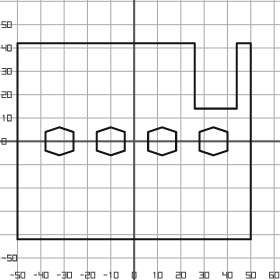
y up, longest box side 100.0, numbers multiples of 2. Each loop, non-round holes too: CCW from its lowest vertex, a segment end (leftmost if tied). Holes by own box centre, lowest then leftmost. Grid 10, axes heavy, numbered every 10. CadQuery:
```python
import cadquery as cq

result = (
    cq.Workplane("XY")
    .moveTo(-50.0, -42.0)
    .lineTo(50.0, -42.0)
    .lineTo(50.0, 42.0)
    .lineTo(44.0, 42.0)
    .lineTo(44.0, 14.0)
    .lineTo(26.0, 14.0)
    .lineTo(26.0, 42.0)
    .lineTo(-50.0, 42.0)
    .close()
    .moveTo(-32.0, -6.0)
    .lineTo(-26.0, -4.0)
    .lineTo(-26.0, 4.0)
    .lineTo(-32.0, 6.0)
    .lineTo(-38.0, 4.0)
    .lineTo(-38.0, -4.0)
    .close()
    .moveTo(-10.0, -6.0)
    .lineTo(-4.0, -4.0)
    .lineTo(-4.0, 4.0)
    .lineTo(-10.0, 6.0)
    .lineTo(-16.0, 4.0)
    .lineTo(-16.0, -4.0)
    .close()
    .moveTo(12.0, -6.0)
    .lineTo(18.0, -4.0)
    .lineTo(18.0, 4.0)
    .lineTo(12.0, 6.0)
    .lineTo(6.0, 4.0)
    .lineTo(6.0, -4.0)
    .close()
    .moveTo(34.0, -6.0)
    .lineTo(40.0, -4.0)
    .lineTo(40.0, 4.0)
    .lineTo(34.0, 6.0)
    .lineTo(28.0, 4.0)
    .lineTo(28.0, -4.0)
    .close()
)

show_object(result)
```